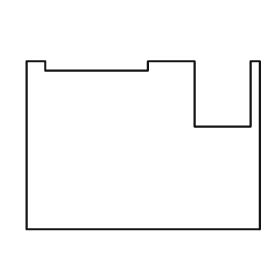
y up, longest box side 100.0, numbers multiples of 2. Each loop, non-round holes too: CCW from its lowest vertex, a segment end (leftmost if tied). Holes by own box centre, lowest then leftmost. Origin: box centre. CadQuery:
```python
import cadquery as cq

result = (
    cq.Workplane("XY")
    .moveTo(-50.0, -36.0)
    .lineTo(50.0, -36.0)
    .lineTo(50.0, 36.0)
    .lineTo(46.0, 36.0)
    .lineTo(46.0, 8.0)
    .lineTo(22.0, 8.0)
    .lineTo(22.0, 36.0)
    .lineTo(2.0, 36.0)
    .lineTo(2.0, 32.0)
    .lineTo(-42.0, 32.0)
    .lineTo(-42.0, 36.0)
    .lineTo(-50.0, 36.0)
    .close()
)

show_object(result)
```